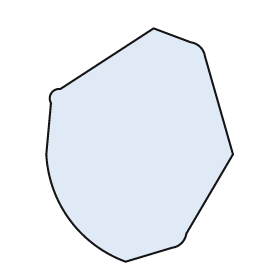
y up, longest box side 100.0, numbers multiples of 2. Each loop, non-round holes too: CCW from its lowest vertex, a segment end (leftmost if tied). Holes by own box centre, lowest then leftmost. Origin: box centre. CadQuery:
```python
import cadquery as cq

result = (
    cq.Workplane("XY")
    .moveTo(-6.0, -50.0)
    .lineTo(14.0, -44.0)
    .threePointArc((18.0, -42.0), (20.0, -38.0))
    .lineTo(40.0, -4.0)
    .lineTo(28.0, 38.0)
    .threePointArc((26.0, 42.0), (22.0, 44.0))
    .lineTo(6.0, 50.0)
    .lineTo(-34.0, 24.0)
    .threePointArc((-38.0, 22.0), (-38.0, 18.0))
    .lineTo(-40.0, -4.0)
    .threePointArc((-30.0, -32.0), (-6.0, -50.0))
    .close()
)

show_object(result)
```